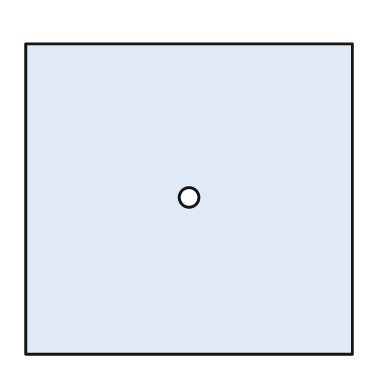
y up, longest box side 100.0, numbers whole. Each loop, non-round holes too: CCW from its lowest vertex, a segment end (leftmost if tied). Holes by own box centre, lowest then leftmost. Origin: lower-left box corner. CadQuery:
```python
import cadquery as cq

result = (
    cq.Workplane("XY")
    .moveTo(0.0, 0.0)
    .lineTo(100.0, 0.0)
    .lineTo(100.0, 95.0)
    .lineTo(0.0, 95.0)
    .close()
    .moveTo(50.0, 48.0)
    .circle(3.0)
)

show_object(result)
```